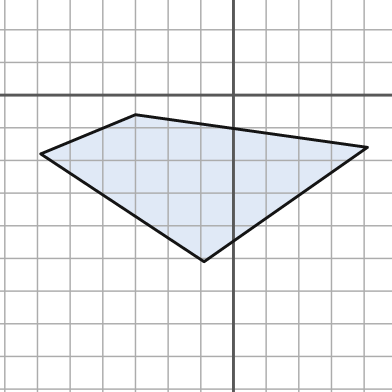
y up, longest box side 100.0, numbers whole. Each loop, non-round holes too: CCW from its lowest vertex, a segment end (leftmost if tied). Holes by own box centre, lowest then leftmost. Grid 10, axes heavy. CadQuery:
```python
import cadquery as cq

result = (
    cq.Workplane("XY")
    .moveTo(-9.0, -51.0)
    .lineTo(41.0, -16.0)
    .lineTo(-30.0, -6.0)
    .lineTo(-59.0, -18.0)
    .close()
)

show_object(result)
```